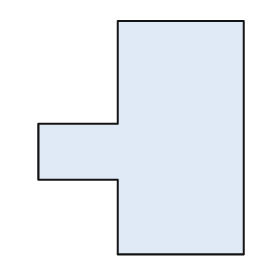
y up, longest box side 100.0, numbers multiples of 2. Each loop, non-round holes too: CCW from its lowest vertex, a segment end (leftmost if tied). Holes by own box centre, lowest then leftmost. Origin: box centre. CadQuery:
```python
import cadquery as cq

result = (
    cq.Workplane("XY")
    .moveTo(-10.0, -50.0)
    .lineTo(44.0, -50.0)
    .lineTo(44.0, 50.0)
    .lineTo(-10.0, 50.0)
    .lineTo(-10.0, 6.0)
    .lineTo(-44.0, 6.0)
    .lineTo(-44.0, -18.0)
    .lineTo(-10.0, -18.0)
    .close()
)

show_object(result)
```